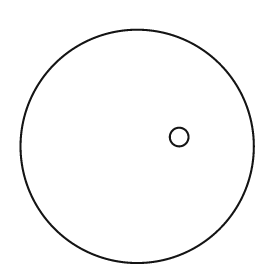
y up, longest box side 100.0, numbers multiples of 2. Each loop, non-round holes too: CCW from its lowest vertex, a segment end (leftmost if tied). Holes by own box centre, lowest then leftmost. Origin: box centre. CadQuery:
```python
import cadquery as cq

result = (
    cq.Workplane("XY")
    .moveTo(0.0, 0.0)
    .circle(50.0)
    .moveTo(18.0, 4.0)
    .circle(4.0)
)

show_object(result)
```